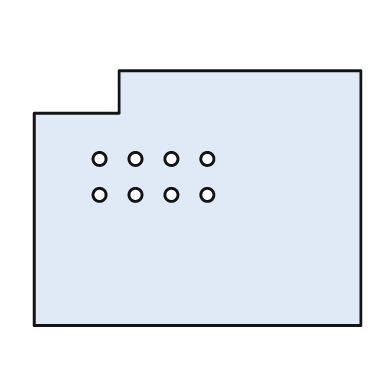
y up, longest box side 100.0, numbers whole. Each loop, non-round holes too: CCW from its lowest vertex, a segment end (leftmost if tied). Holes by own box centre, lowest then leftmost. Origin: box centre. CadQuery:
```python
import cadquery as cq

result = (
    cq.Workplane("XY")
    .moveTo(-50.0, -39.0)
    .lineTo(50.0, -39.0)
    .lineTo(50.0, 39.0)
    .lineTo(-24.0, 39.0)
    .lineTo(-24.0, 26.0)
    .lineTo(-50.0, 26.0)
    .close()
    .moveTo(-30.0, 1.0)
    .circle(2.0)
    .moveTo(-19.0, 1.0)
    .circle(2.0)
    .moveTo(-8.0, 1.0)
    .circle(2.0)
    .moveTo(3.0, 1.0)
    .circle(2.0)
    .moveTo(-30.0, 12.0)
    .circle(2.0)
    .moveTo(-19.0, 12.0)
    .circle(2.0)
    .moveTo(-8.0, 12.0)
    .circle(2.0)
    .moveTo(3.0, 12.0)
    .circle(2.0)
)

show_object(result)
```